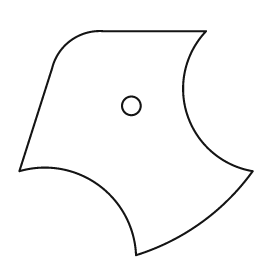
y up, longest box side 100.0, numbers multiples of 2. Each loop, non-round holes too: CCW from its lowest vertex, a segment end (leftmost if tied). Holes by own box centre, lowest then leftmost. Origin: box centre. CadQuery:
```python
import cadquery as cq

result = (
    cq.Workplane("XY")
    .moveTo(0.0, -48.0)
    .threePointArc((28.0, -34.0), (50.0, -12.0))
    .threePointArc((22.0, 12.0), (30.0, 48.0))
    .lineTo(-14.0, 48.0)
    .threePointArc((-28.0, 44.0), (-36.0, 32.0))
    .lineTo(-50.0, -12.0)
    .threePointArc((-16.0, -18.0), (0.0, -48.0))
    .close()
    .moveTo(-2.0, 16.0)
    .circle(4.0)
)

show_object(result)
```